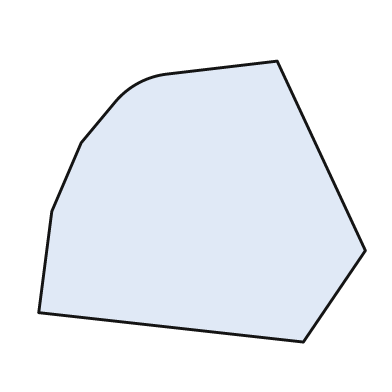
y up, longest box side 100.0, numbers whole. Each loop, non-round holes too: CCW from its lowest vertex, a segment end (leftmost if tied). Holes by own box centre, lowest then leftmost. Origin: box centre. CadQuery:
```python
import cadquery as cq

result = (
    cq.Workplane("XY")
    .moveTo(31.0, -43.0)
    .lineTo(50.0, -15.0)
    .lineTo(23.0, 43.0)
    .lineTo(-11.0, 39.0)
    .threePointArc((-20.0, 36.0), (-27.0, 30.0))
    .lineTo(-37.0, 18.0)
    .lineTo(-46.0, -3.0)
    .lineTo(-50.0, -34.0)
    .close()
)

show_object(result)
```